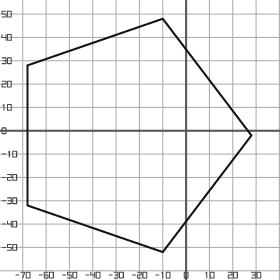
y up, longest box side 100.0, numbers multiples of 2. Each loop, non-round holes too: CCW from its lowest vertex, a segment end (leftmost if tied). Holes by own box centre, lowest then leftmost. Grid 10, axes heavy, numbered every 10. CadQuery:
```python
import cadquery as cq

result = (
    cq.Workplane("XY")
    .moveTo(-10.0, -52.0)
    .lineTo(28.0, -2.0)
    .lineTo(-10.0, 48.0)
    .lineTo(-68.0, 28.0)
    .lineTo(-68.0, -32.0)
    .close()
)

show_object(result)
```